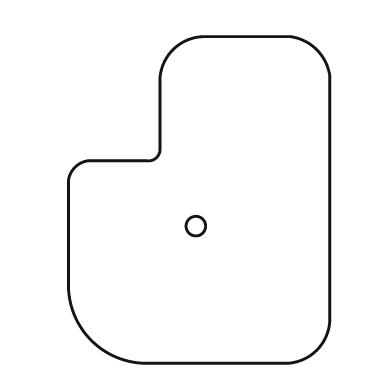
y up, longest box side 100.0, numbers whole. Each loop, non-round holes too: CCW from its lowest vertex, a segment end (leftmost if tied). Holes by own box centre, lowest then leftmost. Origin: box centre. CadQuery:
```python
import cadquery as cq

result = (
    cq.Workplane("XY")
    .moveTo(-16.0, -50.0)
    .lineTo(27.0, -50.0)
    .threePointArc((36.0, -46.0), (40.0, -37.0))
    .lineTo(40.0, 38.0)
    .threePointArc((36.0, 46.0), (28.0, 50.0))
    .lineTo(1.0, 50.0)
    .threePointArc((-8.0, 46.0), (-12.0, 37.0))
    .lineTo(-12.0, 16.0)
    .threePointArc((-13.0, 13.0), (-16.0, 12.0))
    .lineTo(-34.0, 12.0)
    .threePointArc((-38.0, 10.0), (-40.0, 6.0))
    .lineTo(-40.0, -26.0)
    .threePointArc((-33.0, -43.0), (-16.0, -50.0))
    .close()
    .moveTo(-1.0, -8.0)
    .circle(3.0)
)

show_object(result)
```